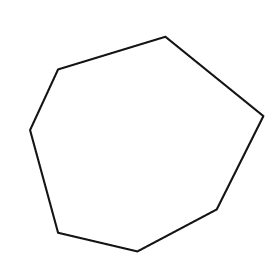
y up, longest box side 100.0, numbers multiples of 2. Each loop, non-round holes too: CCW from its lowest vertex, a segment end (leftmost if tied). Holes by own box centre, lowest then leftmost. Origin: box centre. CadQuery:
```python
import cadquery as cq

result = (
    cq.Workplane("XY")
    .moveTo(-4.0, -46.0)
    .lineTo(30.0, -28.0)
    .lineTo(50.0, 12.0)
    .lineTo(8.0, 46.0)
    .lineTo(-38.0, 32.0)
    .lineTo(-50.0, 6.0)
    .lineTo(-38.0, -38.0)
    .close()
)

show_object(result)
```